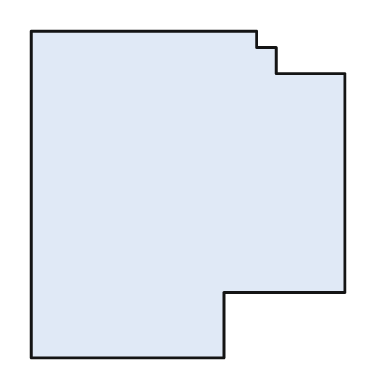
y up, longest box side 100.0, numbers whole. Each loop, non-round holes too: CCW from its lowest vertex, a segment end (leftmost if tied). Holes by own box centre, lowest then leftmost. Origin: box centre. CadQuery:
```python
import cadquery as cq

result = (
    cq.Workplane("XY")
    .moveTo(-48.0, -50.0)
    .lineTo(11.0, -50.0)
    .lineTo(11.0, -30.0)
    .lineTo(48.0, -30.0)
    .lineTo(48.0, 37.0)
    .lineTo(27.0, 37.0)
    .lineTo(27.0, 45.0)
    .lineTo(21.0, 45.0)
    .lineTo(21.0, 50.0)
    .lineTo(-48.0, 50.0)
    .close()
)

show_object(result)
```